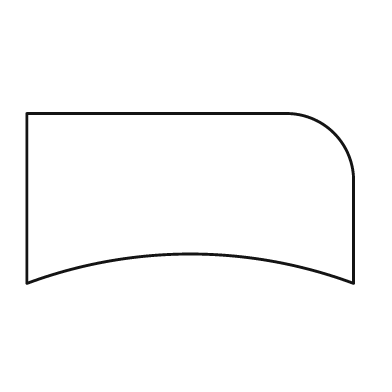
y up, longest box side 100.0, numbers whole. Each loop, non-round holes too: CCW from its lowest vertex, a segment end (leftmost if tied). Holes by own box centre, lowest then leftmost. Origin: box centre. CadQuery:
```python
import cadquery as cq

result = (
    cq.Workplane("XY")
    .moveTo(-50.0, -26.0)
    .threePointArc((0.0, -17.0), (50.0, -26.0))
    .lineTo(50.0, 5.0)
    .threePointArc((44.0, 20.0), (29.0, 26.0))
    .lineTo(-50.0, 26.0)
    .close()
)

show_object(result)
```